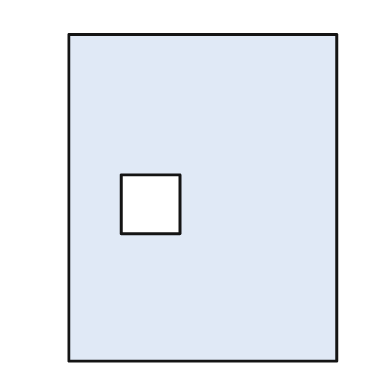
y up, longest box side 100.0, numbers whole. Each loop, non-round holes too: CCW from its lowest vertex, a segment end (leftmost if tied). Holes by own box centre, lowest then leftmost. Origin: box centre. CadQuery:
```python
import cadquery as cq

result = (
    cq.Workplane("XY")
    .moveTo(-41.0, -50.0)
    .lineTo(41.0, -50.0)
    .lineTo(41.0, 50.0)
    .lineTo(-41.0, 50.0)
    .close()
    .moveTo(-25.0, -11.0)
    .lineTo(-7.0, -11.0)
    .lineTo(-7.0, 7.0)
    .lineTo(-25.0, 7.0)
    .close()
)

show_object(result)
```